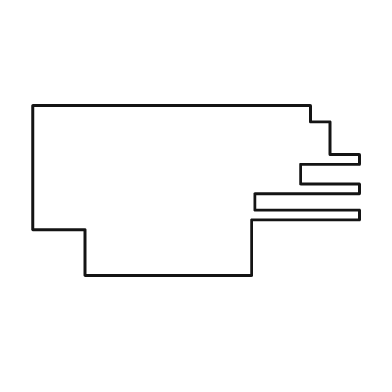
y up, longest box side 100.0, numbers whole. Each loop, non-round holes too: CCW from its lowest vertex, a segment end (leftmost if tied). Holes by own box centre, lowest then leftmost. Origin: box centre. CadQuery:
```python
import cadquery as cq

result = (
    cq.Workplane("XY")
    .moveTo(-34.0, -26.0)
    .lineTo(17.0, -26.0)
    .lineTo(17.0, -9.0)
    .lineTo(50.0, -9.0)
    .lineTo(50.0, -6.0)
    .lineTo(18.0, -6.0)
    .lineTo(18.0, -1.0)
    .lineTo(50.0, -1.0)
    .lineTo(50.0, 2.0)
    .lineTo(32.0, 2.0)
    .lineTo(32.0, 8.0)
    .lineTo(50.0, 8.0)
    .lineTo(50.0, 11.0)
    .lineTo(41.0, 11.0)
    .lineTo(41.0, 21.0)
    .lineTo(35.0, 21.0)
    .lineTo(35.0, 26.0)
    .lineTo(-50.0, 26.0)
    .lineTo(-50.0, -12.0)
    .lineTo(-34.0, -12.0)
    .close()
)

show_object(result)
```